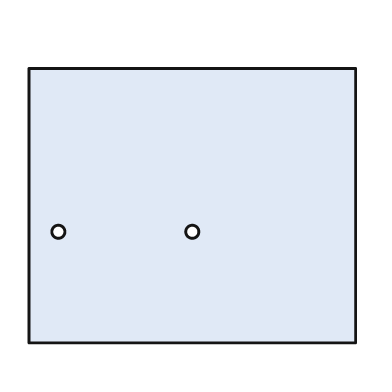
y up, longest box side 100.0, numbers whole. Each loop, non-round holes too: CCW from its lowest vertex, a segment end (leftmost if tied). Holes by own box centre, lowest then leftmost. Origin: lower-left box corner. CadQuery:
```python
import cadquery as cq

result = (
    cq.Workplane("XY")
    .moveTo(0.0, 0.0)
    .lineTo(100.0, 0.0)
    .lineTo(100.0, 84.0)
    .lineTo(0.0, 84.0)
    .close()
    .moveTo(9.0, 34.0)
    .circle(2.0)
    .moveTo(50.0, 34.0)
    .circle(2.0)
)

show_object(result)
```